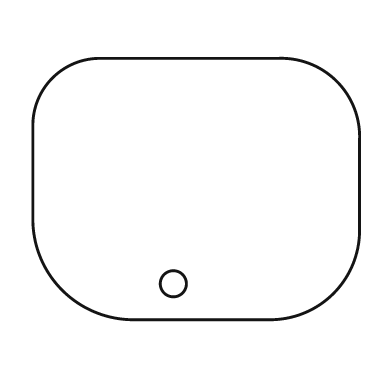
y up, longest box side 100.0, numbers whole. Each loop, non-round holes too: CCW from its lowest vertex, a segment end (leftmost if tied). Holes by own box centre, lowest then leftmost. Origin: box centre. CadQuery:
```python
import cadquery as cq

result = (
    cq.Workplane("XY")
    .moveTo(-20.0, -40.0)
    .lineTo(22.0, -40.0)
    .threePointArc((42.0, -32.0), (50.0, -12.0))
    .lineTo(50.0, 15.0)
    .threePointArc((43.0, 33.0), (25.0, 40.0))
    .lineTo(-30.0, 40.0)
    .threePointArc((-44.0, 34.0), (-50.0, 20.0))
    .lineTo(-50.0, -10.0)
    .threePointArc((-41.0, -31.0), (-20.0, -40.0))
    .close()
    .moveTo(-7.0, -29.0)
    .circle(4.0)
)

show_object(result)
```